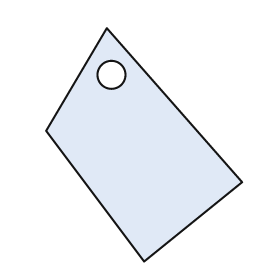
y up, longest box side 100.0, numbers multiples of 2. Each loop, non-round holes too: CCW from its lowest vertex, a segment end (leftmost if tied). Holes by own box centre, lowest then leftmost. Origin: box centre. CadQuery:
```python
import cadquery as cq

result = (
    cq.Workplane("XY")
    .moveTo(0.0, -50.0)
    .lineTo(42.0, -16.0)
    .lineTo(-16.0, 50.0)
    .lineTo(-42.0, 6.0)
    .close()
    .moveTo(-14.0, 30.0)
    .circle(6.0)
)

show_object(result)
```